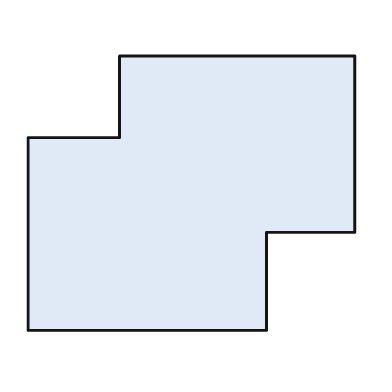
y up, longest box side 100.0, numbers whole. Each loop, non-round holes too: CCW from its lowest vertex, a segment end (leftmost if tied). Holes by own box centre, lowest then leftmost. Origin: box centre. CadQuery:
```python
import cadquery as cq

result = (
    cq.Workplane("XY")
    .moveTo(-50.0, -42.0)
    .lineTo(23.0, -42.0)
    .lineTo(23.0, -12.0)
    .lineTo(50.0, -12.0)
    .lineTo(50.0, 42.0)
    .lineTo(-22.0, 42.0)
    .lineTo(-22.0, 17.0)
    .lineTo(-50.0, 17.0)
    .close()
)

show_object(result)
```